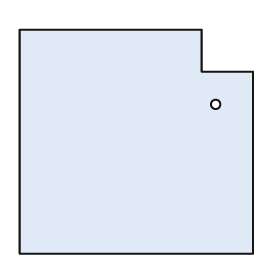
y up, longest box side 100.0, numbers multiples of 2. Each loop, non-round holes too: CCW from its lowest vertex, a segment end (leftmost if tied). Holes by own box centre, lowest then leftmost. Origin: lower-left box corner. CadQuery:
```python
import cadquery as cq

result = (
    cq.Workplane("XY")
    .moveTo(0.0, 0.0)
    .lineTo(100.0, 0.0)
    .lineTo(100.0, 78.0)
    .lineTo(78.0, 78.0)
    .lineTo(78.0, 96.0)
    .lineTo(0.0, 96.0)
    .close()
    .moveTo(84.0, 64.0)
    .circle(2.0)
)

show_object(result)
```